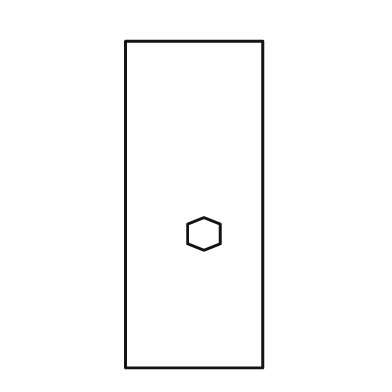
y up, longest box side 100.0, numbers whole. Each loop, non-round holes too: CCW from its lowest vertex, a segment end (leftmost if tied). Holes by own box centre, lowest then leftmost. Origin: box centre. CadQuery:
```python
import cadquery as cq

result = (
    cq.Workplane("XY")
    .moveTo(-21.0, -50.0)
    .lineTo(21.0, -50.0)
    .lineTo(21.0, 50.0)
    .lineTo(-21.0, 50.0)
    .close()
    .moveTo(3.0, -14.0)
    .lineTo(8.0, -12.0)
    .lineTo(8.0, -6.0)
    .lineTo(3.0, -4.0)
    .lineTo(-2.0, -6.0)
    .lineTo(-2.0, -12.0)
    .close()
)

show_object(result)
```